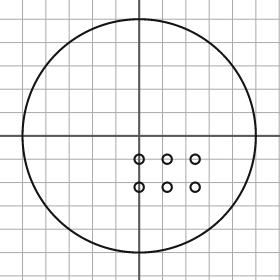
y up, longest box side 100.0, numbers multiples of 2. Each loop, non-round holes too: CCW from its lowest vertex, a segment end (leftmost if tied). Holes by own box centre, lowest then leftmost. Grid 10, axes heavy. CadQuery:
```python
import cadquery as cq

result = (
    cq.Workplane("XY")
    .moveTo(0.0, 0.0)
    .circle(50.0)
    .moveTo(0.0, -22.0)
    .circle(2.0)
    .moveTo(12.0, -22.0)
    .circle(2.0)
    .moveTo(24.0, -22.0)
    .circle(2.0)
    .moveTo(0.0, -10.0)
    .circle(2.0)
    .moveTo(12.0, -10.0)
    .circle(2.0)
    .moveTo(24.0, -10.0)
    .circle(2.0)
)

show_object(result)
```